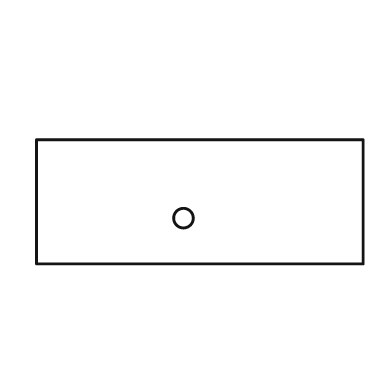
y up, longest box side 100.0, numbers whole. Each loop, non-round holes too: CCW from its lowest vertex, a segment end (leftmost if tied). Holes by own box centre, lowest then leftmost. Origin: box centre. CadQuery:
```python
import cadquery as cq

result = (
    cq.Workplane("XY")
    .moveTo(-50.0, -19.0)
    .lineTo(50.0, -19.0)
    .lineTo(50.0, 19.0)
    .lineTo(-50.0, 19.0)
    .close()
    .moveTo(-5.0, -5.0)
    .circle(3.0)
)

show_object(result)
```